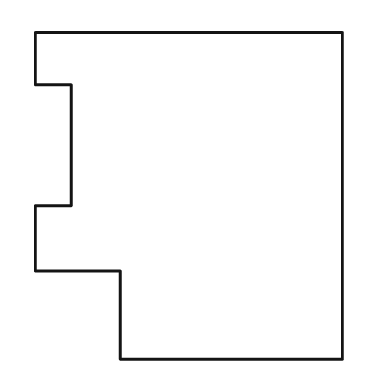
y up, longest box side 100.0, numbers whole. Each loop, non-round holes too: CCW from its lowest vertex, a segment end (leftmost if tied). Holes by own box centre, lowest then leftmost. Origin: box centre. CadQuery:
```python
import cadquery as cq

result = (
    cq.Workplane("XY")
    .moveTo(-21.0, -50.0)
    .lineTo(47.0, -50.0)
    .lineTo(47.0, 50.0)
    .lineTo(-47.0, 50.0)
    .lineTo(-47.0, 34.0)
    .lineTo(-36.0, 34.0)
    .lineTo(-36.0, -3.0)
    .lineTo(-47.0, -3.0)
    .lineTo(-47.0, -23.0)
    .lineTo(-21.0, -23.0)
    .close()
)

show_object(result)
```